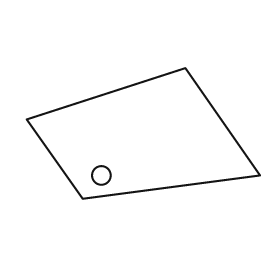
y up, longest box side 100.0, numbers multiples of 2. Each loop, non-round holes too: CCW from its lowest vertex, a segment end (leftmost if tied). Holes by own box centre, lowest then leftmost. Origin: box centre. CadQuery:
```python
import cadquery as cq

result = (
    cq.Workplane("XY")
    .moveTo(-26.0, -28.0)
    .lineTo(50.0, -18.0)
    .lineTo(18.0, 28.0)
    .lineTo(-50.0, 6.0)
    .close()
    .moveTo(-18.0, -18.0)
    .circle(4.0)
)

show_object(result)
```